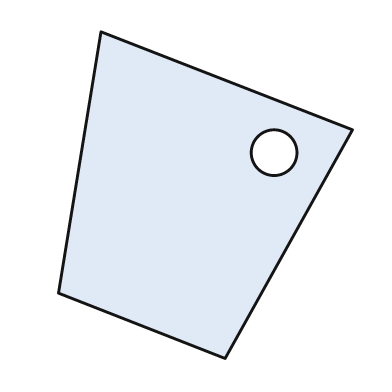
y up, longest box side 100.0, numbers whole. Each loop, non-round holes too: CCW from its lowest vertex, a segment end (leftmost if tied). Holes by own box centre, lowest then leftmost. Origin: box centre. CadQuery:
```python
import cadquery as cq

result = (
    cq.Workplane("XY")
    .moveTo(6.0, -50.0)
    .lineTo(45.0, 20.0)
    .lineTo(-32.0, 50.0)
    .lineTo(-45.0, -30.0)
    .close()
    .moveTo(21.0, 13.0)
    .circle(7.0)
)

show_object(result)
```